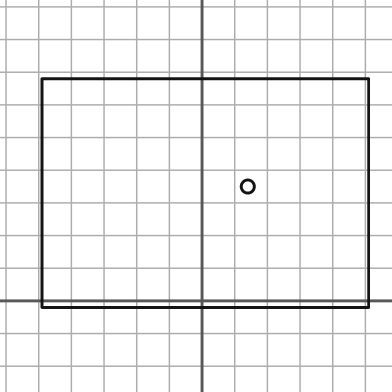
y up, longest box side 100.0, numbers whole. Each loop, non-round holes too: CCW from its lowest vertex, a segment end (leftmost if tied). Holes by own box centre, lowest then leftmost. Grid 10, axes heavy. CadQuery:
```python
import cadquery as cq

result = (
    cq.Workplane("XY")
    .moveTo(-49.0, -2.0)
    .lineTo(51.0, -2.0)
    .lineTo(51.0, 68.0)
    .lineTo(-49.0, 68.0)
    .close()
    .moveTo(14.0, 35.0)
    .circle(2.0)
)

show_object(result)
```